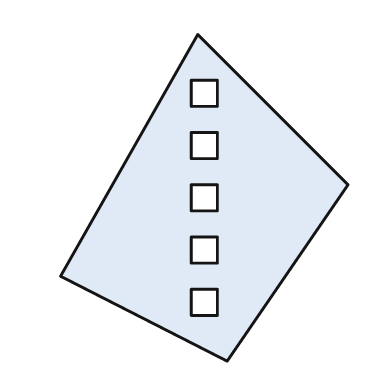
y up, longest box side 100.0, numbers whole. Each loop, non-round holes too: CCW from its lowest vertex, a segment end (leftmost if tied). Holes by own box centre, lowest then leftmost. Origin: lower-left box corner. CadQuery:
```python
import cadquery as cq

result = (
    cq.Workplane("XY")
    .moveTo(51.0, 0.0)
    .lineTo(88.0, 54.0)
    .lineTo(42.0, 100.0)
    .lineTo(0.0, 26.0)
    .close()
    .moveTo(40.0, 14.0)
    .lineTo(48.0, 14.0)
    .lineTo(48.0, 22.0)
    .lineTo(40.0, 22.0)
    .close()
    .moveTo(40.0, 30.0)
    .lineTo(48.0, 30.0)
    .lineTo(48.0, 38.0)
    .lineTo(40.0, 38.0)
    .close()
    .moveTo(40.0, 46.0)
    .lineTo(48.0, 46.0)
    .lineTo(48.0, 54.0)
    .lineTo(40.0, 54.0)
    .close()
    .moveTo(40.0, 62.0)
    .lineTo(48.0, 62.0)
    .lineTo(48.0, 70.0)
    .lineTo(40.0, 70.0)
    .close()
    .moveTo(40.0, 78.0)
    .lineTo(48.0, 78.0)
    .lineTo(48.0, 86.0)
    .lineTo(40.0, 86.0)
    .close()
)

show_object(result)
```